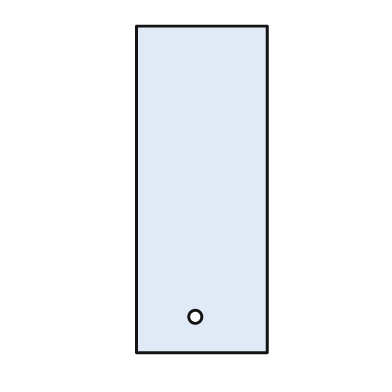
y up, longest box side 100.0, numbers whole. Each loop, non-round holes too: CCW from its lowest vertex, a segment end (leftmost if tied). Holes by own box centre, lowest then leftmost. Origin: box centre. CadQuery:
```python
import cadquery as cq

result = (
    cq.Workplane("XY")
    .moveTo(-20.0, -50.0)
    .lineTo(20.0, -50.0)
    .lineTo(20.0, 50.0)
    .lineTo(-20.0, 50.0)
    .close()
    .moveTo(-2.0, -39.0)
    .circle(2.0)
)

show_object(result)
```